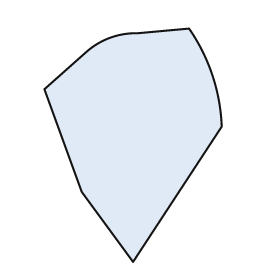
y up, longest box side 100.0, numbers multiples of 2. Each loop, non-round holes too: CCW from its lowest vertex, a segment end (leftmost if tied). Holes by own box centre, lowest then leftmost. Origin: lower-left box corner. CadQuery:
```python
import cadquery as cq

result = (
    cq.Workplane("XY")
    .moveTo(38.0, 0.0)
    .lineTo(76.0, 58.0)
    .threePointArc((72.0, 80.0), (62.0, 100.0))
    .lineTo(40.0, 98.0)
    .threePointArc((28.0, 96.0), (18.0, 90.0))
    .lineTo(0.0, 74.0)
    .lineTo(16.0, 30.0)
    .close()
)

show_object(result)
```